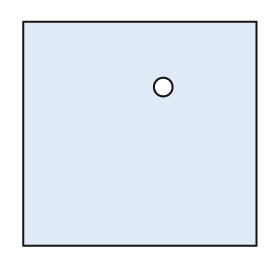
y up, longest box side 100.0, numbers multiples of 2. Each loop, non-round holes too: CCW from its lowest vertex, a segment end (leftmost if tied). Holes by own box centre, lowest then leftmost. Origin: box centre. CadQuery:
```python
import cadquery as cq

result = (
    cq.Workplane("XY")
    .moveTo(-50.0, -48.0)
    .lineTo(50.0, -48.0)
    .lineTo(50.0, 48.0)
    .lineTo(-50.0, 48.0)
    .close()
    .moveTo(10.0, 20.0)
    .circle(4.0)
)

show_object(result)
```